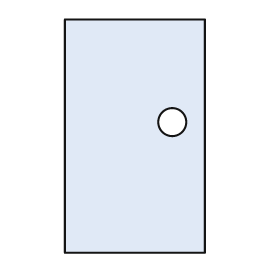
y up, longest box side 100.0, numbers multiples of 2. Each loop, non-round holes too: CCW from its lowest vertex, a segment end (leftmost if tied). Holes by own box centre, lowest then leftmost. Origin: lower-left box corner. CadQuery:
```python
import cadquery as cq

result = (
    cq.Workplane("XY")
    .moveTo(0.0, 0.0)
    .lineTo(60.0, 0.0)
    .lineTo(60.0, 100.0)
    .lineTo(0.0, 100.0)
    .close()
    .moveTo(46.0, 56.0)
    .circle(6.0)
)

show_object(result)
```